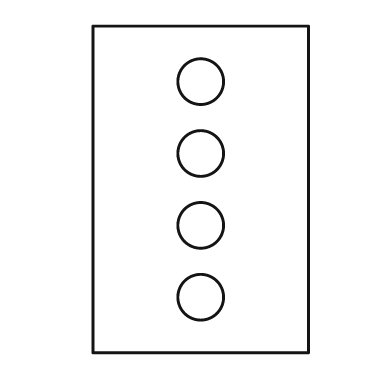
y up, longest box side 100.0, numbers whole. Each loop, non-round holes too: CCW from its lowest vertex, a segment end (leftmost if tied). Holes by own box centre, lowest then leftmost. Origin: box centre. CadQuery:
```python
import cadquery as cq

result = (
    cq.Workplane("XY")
    .moveTo(-33.0, -50.0)
    .lineTo(33.0, -50.0)
    .lineTo(33.0, 50.0)
    .lineTo(-33.0, 50.0)
    .close()
    .moveTo(0.0, -33.0)
    .circle(7.0)
    .moveTo(0.0, -11.0)
    .circle(7.0)
    .moveTo(0.0, 11.0)
    .circle(7.0)
    .moveTo(0.0, 33.0)
    .circle(7.0)
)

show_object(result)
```